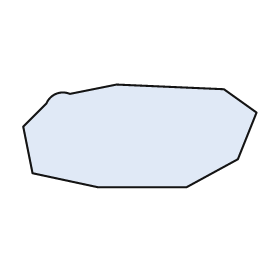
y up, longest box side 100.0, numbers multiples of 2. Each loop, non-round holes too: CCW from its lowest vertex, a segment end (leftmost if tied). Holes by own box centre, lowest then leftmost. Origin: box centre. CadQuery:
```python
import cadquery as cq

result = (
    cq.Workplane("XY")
    .moveTo(-18.0, -22.0)
    .lineTo(20.0, -22.0)
    .lineTo(42.0, -10.0)
    .lineTo(50.0, 10.0)
    .lineTo(36.0, 20.0)
    .lineTo(-10.0, 22.0)
    .lineTo(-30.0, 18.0)
    .threePointArc((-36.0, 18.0), (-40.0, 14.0))
    .lineTo(-50.0, 4.0)
    .lineTo(-46.0, -16.0)
    .close()
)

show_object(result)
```